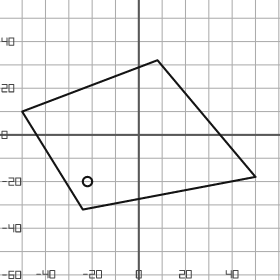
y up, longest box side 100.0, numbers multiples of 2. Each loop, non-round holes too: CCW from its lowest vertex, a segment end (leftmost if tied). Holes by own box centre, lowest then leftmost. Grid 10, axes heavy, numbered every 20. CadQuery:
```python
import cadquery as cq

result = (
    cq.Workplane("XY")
    .moveTo(-24.0, -32.0)
    .lineTo(50.0, -18.0)
    .lineTo(8.0, 32.0)
    .lineTo(-50.0, 10.0)
    .close()
    .moveTo(-22.0, -20.0)
    .circle(2.0)
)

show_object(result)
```